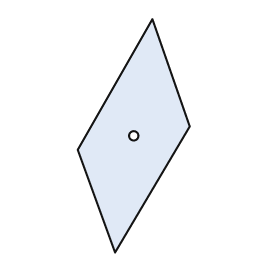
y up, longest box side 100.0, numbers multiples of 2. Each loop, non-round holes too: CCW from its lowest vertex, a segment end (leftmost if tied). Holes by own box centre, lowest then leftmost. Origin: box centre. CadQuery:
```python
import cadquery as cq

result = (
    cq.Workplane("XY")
    .moveTo(-8.0, -50.0)
    .lineTo(24.0, 4.0)
    .lineTo(8.0, 50.0)
    .lineTo(-24.0, -6.0)
    .close()
    .moveTo(0.0, 0.0)
    .circle(2.0)
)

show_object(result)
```